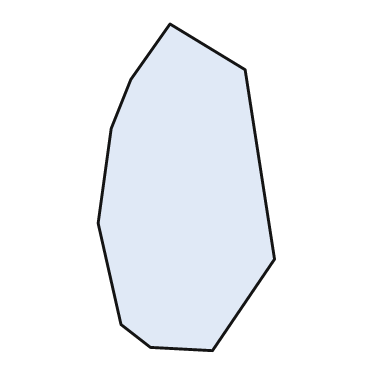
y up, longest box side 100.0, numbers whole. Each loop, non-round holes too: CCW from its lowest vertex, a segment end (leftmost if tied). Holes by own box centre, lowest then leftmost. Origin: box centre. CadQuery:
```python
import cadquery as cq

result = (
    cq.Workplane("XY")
    .moveTo(8.0, -50.0)
    .lineTo(27.0, -22.0)
    .lineTo(18.0, 36.0)
    .lineTo(-5.0, 50.0)
    .lineTo(-17.0, 33.0)
    .lineTo(-23.0, 18.0)
    .lineTo(-27.0, -11.0)
    .lineTo(-20.0, -42.0)
    .lineTo(-11.0, -49.0)
    .close()
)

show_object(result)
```